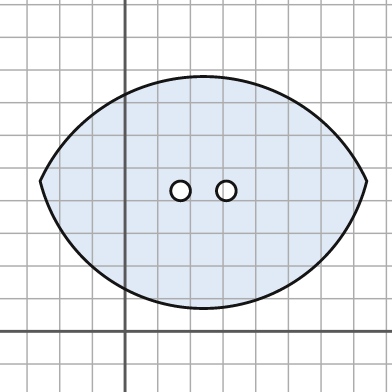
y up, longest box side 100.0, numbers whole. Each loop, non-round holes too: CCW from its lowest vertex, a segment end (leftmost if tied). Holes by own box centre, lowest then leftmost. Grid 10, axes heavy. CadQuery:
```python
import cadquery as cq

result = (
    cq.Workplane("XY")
    .moveTo(-26.0, 46.0)
    .threePointArc((24.0, 7.0), (74.0, 46.0))
    .threePointArc((24.0, 78.0), (-26.0, 46.0))
    .close()
    .moveTo(17.0, 43.0)
    .circle(3.0)
    .moveTo(31.0, 43.0)
    .circle(3.0)
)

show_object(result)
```